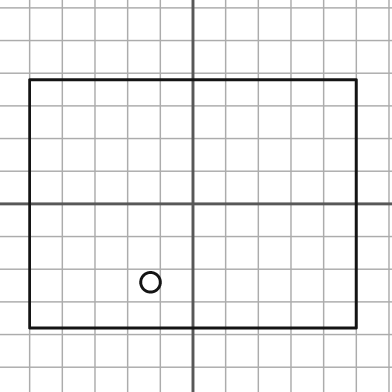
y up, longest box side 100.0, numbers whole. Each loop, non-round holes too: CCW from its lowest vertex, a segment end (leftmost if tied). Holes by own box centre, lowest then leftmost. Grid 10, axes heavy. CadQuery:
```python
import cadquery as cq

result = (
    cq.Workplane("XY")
    .moveTo(-50.0, -38.0)
    .lineTo(50.0, -38.0)
    .lineTo(50.0, 38.0)
    .lineTo(-50.0, 38.0)
    .close()
    .moveTo(-13.0, -24.0)
    .circle(3.0)
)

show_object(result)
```